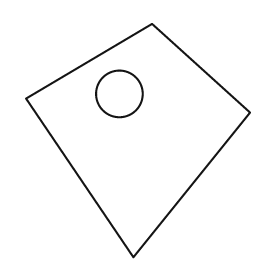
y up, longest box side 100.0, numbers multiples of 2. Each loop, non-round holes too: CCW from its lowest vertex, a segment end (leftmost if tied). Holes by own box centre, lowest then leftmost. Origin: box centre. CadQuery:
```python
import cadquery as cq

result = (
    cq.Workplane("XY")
    .moveTo(-2.0, -50.0)
    .lineTo(48.0, 12.0)
    .lineTo(6.0, 50.0)
    .lineTo(-48.0, 18.0)
    .close()
    .moveTo(-8.0, 20.0)
    .circle(10.0)
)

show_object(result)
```